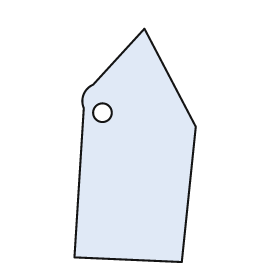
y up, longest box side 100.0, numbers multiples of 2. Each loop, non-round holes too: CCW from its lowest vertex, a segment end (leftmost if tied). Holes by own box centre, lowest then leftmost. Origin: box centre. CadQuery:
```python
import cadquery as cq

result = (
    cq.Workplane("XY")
    .moveTo(20.0, -50.0)
    .lineTo(26.0, 8.0)
    .lineTo(4.0, 50.0)
    .lineTo(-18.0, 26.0)
    .threePointArc((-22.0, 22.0), (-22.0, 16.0))
    .lineTo(-26.0, -48.0)
    .close()
    .moveTo(-14.0, 14.0)
    .circle(4.0)
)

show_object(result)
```